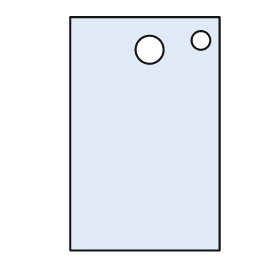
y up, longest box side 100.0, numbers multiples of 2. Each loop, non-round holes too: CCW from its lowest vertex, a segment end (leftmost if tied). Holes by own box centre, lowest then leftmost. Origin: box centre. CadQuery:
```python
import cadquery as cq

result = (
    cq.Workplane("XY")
    .moveTo(-32.0, -50.0)
    .lineTo(32.0, -50.0)
    .lineTo(32.0, 50.0)
    .lineTo(-32.0, 50.0)
    .close()
    .moveTo(2.0, 36.0)
    .circle(6.0)
    .moveTo(24.0, 40.0)
    .circle(4.0)
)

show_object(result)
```